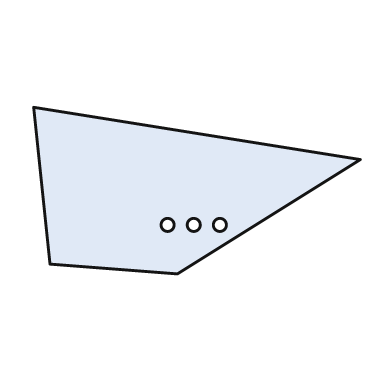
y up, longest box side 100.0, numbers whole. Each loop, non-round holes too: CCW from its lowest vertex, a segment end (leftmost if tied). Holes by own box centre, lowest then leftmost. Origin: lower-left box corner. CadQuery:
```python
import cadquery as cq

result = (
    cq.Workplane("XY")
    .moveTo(44.0, 0.0)
    .lineTo(100.0, 35.0)
    .lineTo(0.0, 51.0)
    .lineTo(5.0, 3.0)
    .close()
    .moveTo(41.0, 15.0)
    .circle(2.0)
    .moveTo(49.0, 15.0)
    .circle(2.0)
    .moveTo(57.0, 15.0)
    .circle(2.0)
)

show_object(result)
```